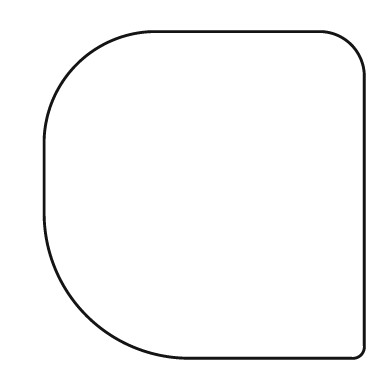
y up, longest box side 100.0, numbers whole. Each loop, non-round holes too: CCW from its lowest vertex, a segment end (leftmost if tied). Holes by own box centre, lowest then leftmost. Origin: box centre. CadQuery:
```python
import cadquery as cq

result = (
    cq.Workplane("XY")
    .moveTo(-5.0, -50.0)
    .lineTo(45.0, -50.0)
    .threePointArc((48.0, -49.0), (49.0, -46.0))
    .lineTo(49.0, 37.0)
    .threePointArc((45.0, 46.0), (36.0, 50.0))
    .lineTo(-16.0, 50.0)
    .threePointArc((-39.0, 40.0), (-49.0, 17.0))
    .lineTo(-49.0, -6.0)
    .threePointArc((-36.0, -37.0), (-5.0, -50.0))
    .close()
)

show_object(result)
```